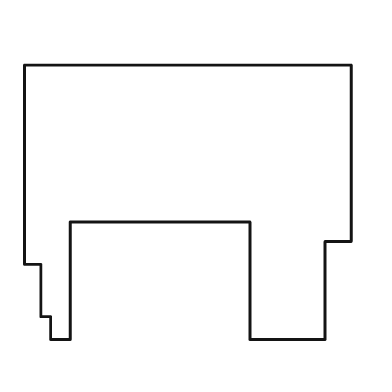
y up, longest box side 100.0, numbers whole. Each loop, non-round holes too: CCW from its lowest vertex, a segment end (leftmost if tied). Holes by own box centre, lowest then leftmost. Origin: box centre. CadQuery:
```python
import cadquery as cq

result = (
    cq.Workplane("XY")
    .moveTo(-42.0, -42.0)
    .lineTo(-36.0, -42.0)
    .lineTo(-36.0, -6.0)
    .lineTo(19.0, -6.0)
    .lineTo(19.0, -42.0)
    .lineTo(42.0, -42.0)
    .lineTo(42.0, -12.0)
    .lineTo(50.0, -12.0)
    .lineTo(50.0, 42.0)
    .lineTo(-50.0, 42.0)
    .lineTo(-50.0, -19.0)
    .lineTo(-45.0, -19.0)
    .lineTo(-45.0, -35.0)
    .lineTo(-42.0, -35.0)
    .close()
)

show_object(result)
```